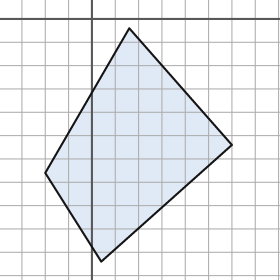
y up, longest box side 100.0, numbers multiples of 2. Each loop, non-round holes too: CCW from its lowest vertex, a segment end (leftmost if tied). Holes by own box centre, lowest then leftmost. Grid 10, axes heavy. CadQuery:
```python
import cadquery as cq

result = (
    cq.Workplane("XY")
    .moveTo(4.0, -104.0)
    .lineTo(60.0, -54.0)
    .lineTo(16.0, -4.0)
    .lineTo(-20.0, -66.0)
    .close()
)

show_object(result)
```